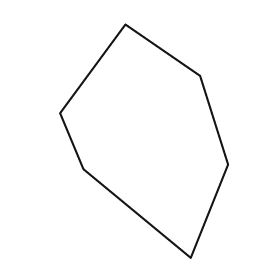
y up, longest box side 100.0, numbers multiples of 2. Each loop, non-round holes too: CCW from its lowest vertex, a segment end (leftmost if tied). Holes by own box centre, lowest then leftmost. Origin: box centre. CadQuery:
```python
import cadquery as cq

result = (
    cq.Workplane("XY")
    .moveTo(20.0, -50.0)
    .lineTo(36.0, -10.0)
    .lineTo(24.0, 28.0)
    .lineTo(-8.0, 50.0)
    .lineTo(-36.0, 12.0)
    .lineTo(-26.0, -12.0)
    .close()
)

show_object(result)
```